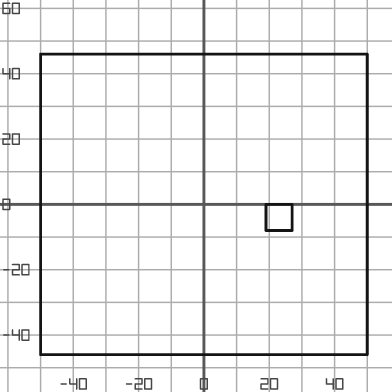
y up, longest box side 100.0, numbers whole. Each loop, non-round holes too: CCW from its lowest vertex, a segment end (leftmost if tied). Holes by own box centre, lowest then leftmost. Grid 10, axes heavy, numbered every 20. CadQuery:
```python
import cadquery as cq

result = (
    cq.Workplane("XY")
    .moveTo(-50.0, -46.0)
    .lineTo(50.0, -46.0)
    .lineTo(50.0, 46.0)
    .lineTo(-50.0, 46.0)
    .close()
    .moveTo(19.0, -8.0)
    .lineTo(27.0, -8.0)
    .lineTo(27.0, 0.0)
    .lineTo(19.0, 0.0)
    .close()
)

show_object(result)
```